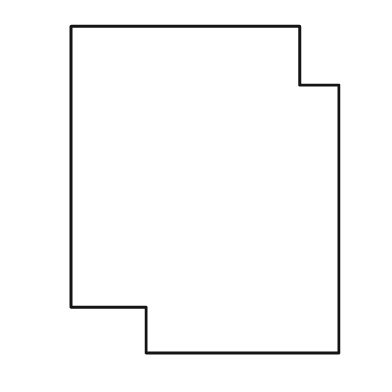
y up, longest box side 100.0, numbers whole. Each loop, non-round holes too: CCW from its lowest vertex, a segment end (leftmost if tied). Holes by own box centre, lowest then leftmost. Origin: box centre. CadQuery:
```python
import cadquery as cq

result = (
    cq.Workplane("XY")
    .moveTo(-18.0, -50.0)
    .lineTo(41.0, -50.0)
    .lineTo(41.0, 32.0)
    .lineTo(29.0, 32.0)
    .lineTo(29.0, 50.0)
    .lineTo(-41.0, 50.0)
    .lineTo(-41.0, -36.0)
    .lineTo(-18.0, -36.0)
    .close()
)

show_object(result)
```